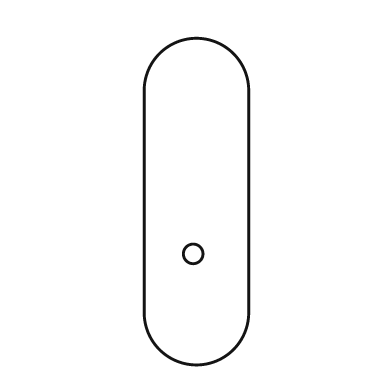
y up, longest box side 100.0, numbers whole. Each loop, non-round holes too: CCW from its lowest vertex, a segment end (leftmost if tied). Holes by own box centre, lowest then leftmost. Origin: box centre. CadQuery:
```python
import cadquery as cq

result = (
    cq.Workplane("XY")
    .moveTo(-16.0, -34.0)
    .threePointArc((0.0, -50.0), (16.0, -34.0))
    .lineTo(16.0, 34.0)
    .threePointArc((0.0, 50.0), (-16.0, 34.0))
    .close()
    .moveTo(-1.0, -16.0)
    .circle(3.0)
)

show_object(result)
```